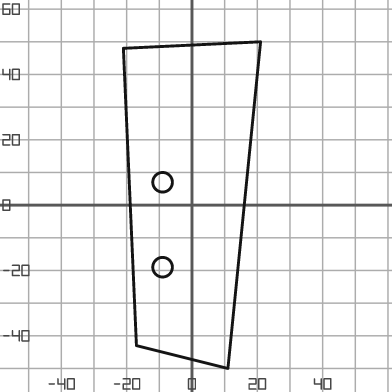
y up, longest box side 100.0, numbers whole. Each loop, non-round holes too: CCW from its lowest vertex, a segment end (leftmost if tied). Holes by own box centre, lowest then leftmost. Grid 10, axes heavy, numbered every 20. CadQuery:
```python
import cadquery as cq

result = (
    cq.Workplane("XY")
    .moveTo(11.0, -50.0)
    .lineTo(21.0, 50.0)
    .lineTo(-21.0, 48.0)
    .lineTo(-17.0, -43.0)
    .close()
    .moveTo(-9.0, -19.0)
    .circle(3.0)
    .moveTo(-9.0, 7.0)
    .circle(3.0)
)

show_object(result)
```